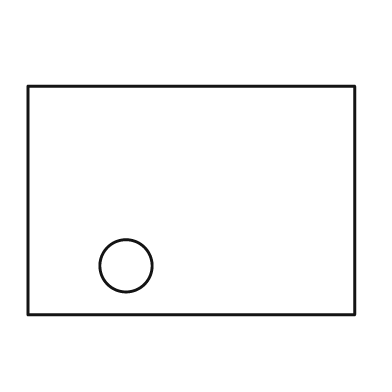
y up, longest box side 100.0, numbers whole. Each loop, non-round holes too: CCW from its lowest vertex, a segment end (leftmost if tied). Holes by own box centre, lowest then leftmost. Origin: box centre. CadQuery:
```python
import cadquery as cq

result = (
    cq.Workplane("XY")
    .moveTo(-50.0, -35.0)
    .lineTo(50.0, -35.0)
    .lineTo(50.0, 35.0)
    .lineTo(-50.0, 35.0)
    .close()
    .moveTo(-20.0, -20.0)
    .circle(8.0)
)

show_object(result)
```